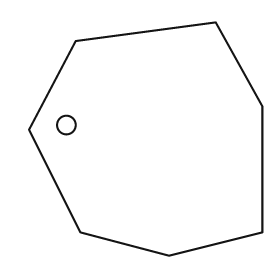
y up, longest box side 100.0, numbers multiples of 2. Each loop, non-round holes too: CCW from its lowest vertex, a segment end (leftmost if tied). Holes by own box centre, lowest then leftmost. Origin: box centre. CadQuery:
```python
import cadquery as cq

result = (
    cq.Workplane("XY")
    .moveTo(10.0, -50.0)
    .lineTo(50.0, -40.0)
    .lineTo(50.0, 14.0)
    .lineTo(30.0, 50.0)
    .lineTo(-30.0, 42.0)
    .lineTo(-50.0, 4.0)
    .lineTo(-28.0, -40.0)
    .close()
    .moveTo(-34.0, 6.0)
    .circle(4.0)
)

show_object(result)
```